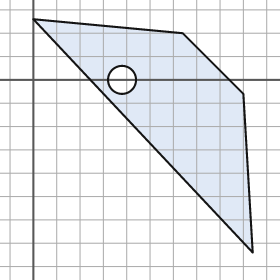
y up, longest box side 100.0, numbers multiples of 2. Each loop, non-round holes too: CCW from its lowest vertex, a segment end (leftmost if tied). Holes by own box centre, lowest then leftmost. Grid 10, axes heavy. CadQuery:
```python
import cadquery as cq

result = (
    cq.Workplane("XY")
    .moveTo(94.0, -74.0)
    .lineTo(90.0, -6.0)
    .lineTo(64.0, 20.0)
    .lineTo(0.0, 26.0)
    .close()
    .moveTo(38.0, 0.0)
    .circle(6.0)
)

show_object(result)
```